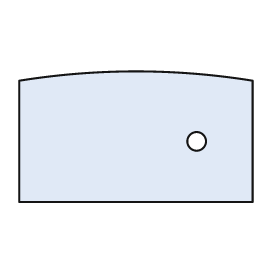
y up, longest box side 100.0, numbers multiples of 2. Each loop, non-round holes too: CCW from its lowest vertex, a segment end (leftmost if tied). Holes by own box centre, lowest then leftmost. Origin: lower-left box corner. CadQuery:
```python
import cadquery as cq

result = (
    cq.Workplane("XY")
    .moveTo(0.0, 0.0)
    .lineTo(100.0, 0.0)
    .lineTo(100.0, 52.0)
    .threePointArc((50.0, 56.0), (0.0, 52.0))
    .close()
    .moveTo(76.0, 26.0)
    .circle(4.0)
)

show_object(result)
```